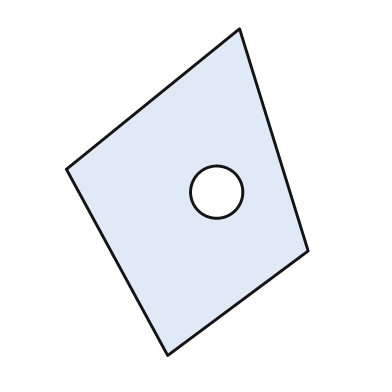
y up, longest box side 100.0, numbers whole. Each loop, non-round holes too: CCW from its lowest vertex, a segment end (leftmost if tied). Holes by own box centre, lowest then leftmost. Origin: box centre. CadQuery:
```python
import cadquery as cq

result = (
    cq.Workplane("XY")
    .moveTo(-6.0, -50.0)
    .lineTo(37.0, -18.0)
    .lineTo(16.0, 50.0)
    .lineTo(-37.0, 7.0)
    .close()
    .moveTo(9.0, 0.0)
    .circle(8.0)
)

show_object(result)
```